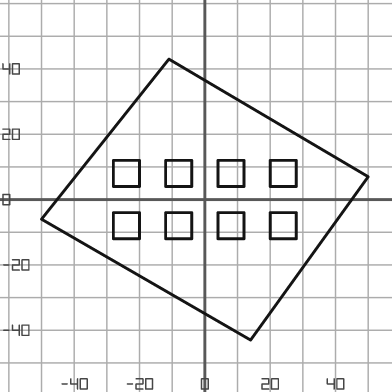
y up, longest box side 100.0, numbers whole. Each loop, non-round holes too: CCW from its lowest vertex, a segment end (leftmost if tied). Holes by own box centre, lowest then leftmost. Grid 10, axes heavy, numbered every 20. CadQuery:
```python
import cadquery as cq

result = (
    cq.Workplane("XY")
    .moveTo(14.0, -43.0)
    .lineTo(50.0, 7.0)
    .lineTo(-11.0, 43.0)
    .lineTo(-50.0, -6.0)
    .close()
    .moveTo(-28.0, -12.0)
    .lineTo(-20.0, -12.0)
    .lineTo(-20.0, -4.0)
    .lineTo(-28.0, -4.0)
    .close()
    .moveTo(-12.0, -12.0)
    .lineTo(-4.0, -12.0)
    .lineTo(-4.0, -4.0)
    .lineTo(-12.0, -4.0)
    .close()
    .moveTo(4.0, -12.0)
    .lineTo(12.0, -12.0)
    .lineTo(12.0, -4.0)
    .lineTo(4.0, -4.0)
    .close()
    .moveTo(20.0, -12.0)
    .lineTo(28.0, -12.0)
    .lineTo(28.0, -4.0)
    .lineTo(20.0, -4.0)
    .close()
    .moveTo(-28.0, 4.0)
    .lineTo(-20.0, 4.0)
    .lineTo(-20.0, 12.0)
    .lineTo(-28.0, 12.0)
    .close()
    .moveTo(-12.0, 4.0)
    .lineTo(-4.0, 4.0)
    .lineTo(-4.0, 12.0)
    .lineTo(-12.0, 12.0)
    .close()
    .moveTo(4.0, 4.0)
    .lineTo(12.0, 4.0)
    .lineTo(12.0, 12.0)
    .lineTo(4.0, 12.0)
    .close()
    .moveTo(20.0, 4.0)
    .lineTo(28.0, 4.0)
    .lineTo(28.0, 12.0)
    .lineTo(20.0, 12.0)
    .close()
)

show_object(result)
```